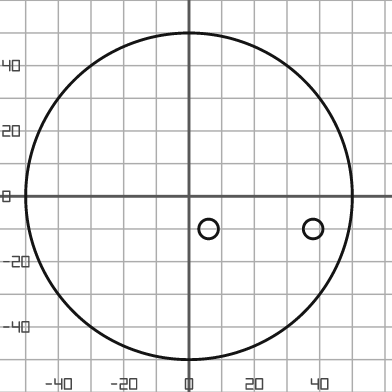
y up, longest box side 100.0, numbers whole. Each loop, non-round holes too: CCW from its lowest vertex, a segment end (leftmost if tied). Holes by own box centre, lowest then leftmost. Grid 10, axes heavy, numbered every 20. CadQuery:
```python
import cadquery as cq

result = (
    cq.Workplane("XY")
    .moveTo(0.0, 0.0)
    .circle(50.0)
    .moveTo(6.0, -10.0)
    .circle(3.0)
    .moveTo(38.0, -10.0)
    .circle(3.0)
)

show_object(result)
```